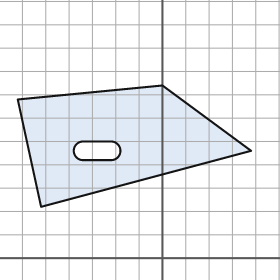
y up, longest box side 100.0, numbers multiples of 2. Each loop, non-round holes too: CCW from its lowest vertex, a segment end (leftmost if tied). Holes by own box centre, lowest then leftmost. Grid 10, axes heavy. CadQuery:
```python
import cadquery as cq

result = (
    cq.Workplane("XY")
    .moveTo(-52.0, 22.0)
    .lineTo(38.0, 46.0)
    .lineTo(0.0, 74.0)
    .lineTo(-62.0, 68.0)
    .close()
    .moveTo(-34.0, 42.0)
    .lineTo(-22.0, 42.0)
    .threePointArc((-18.0, 46.0), (-22.0, 50.0))
    .lineTo(-34.0, 50.0)
    .threePointArc((-38.0, 46.0), (-34.0, 42.0))
    .close()
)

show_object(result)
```